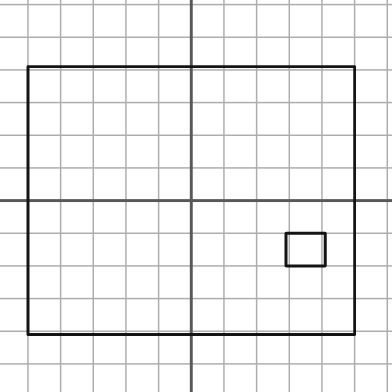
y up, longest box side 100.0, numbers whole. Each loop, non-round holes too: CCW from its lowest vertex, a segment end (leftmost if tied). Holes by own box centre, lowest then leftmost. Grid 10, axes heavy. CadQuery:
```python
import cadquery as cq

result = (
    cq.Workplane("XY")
    .moveTo(-50.0, -41.0)
    .lineTo(50.0, -41.0)
    .lineTo(50.0, 41.0)
    .lineTo(-50.0, 41.0)
    .close()
    .moveTo(29.0, -20.0)
    .lineTo(41.0, -20.0)
    .lineTo(41.0, -10.0)
    .lineTo(29.0, -10.0)
    .close()
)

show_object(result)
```